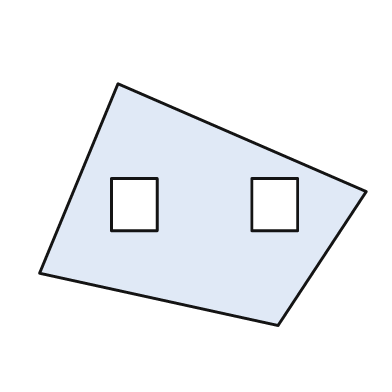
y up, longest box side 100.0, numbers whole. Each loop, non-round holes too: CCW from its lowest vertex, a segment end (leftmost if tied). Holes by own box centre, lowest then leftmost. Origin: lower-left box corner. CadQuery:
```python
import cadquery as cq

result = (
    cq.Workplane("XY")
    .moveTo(73.0, 0.0)
    .lineTo(100.0, 41.0)
    .lineTo(24.0, 74.0)
    .lineTo(0.0, 16.0)
    .close()
    .moveTo(22.0, 29.0)
    .lineTo(36.0, 29.0)
    .lineTo(36.0, 45.0)
    .lineTo(22.0, 45.0)
    .close()
    .moveTo(65.0, 29.0)
    .lineTo(79.0, 29.0)
    .lineTo(79.0, 45.0)
    .lineTo(65.0, 45.0)
    .close()
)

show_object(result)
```